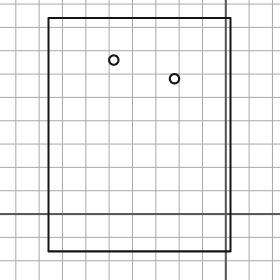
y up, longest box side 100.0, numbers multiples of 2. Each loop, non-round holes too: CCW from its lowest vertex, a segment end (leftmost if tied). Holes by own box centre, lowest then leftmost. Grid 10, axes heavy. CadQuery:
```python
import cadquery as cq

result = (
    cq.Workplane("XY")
    .moveTo(-76.0, -16.0)
    .lineTo(2.0, -16.0)
    .lineTo(2.0, 84.0)
    .lineTo(-76.0, 84.0)
    .close()
    .moveTo(-22.0, 58.0)
    .circle(2.0)
    .moveTo(-48.0, 66.0)
    .circle(2.0)
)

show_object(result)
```